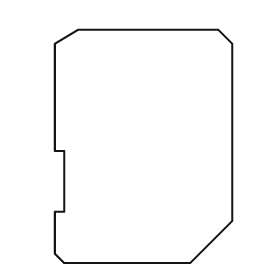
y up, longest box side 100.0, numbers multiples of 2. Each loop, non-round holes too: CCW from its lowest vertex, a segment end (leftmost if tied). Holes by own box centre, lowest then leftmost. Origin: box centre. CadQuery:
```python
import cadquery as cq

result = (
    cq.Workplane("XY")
    .moveTo(-34.0, -50.0)
    .lineTo(20.0, -50.0)
    .lineTo(38.0, -32.0)
    .lineTo(38.0, 44.0)
    .lineTo(32.0, 50.0)
    .lineTo(-28.0, 50.0)
    .lineTo(-38.0, 44.0)
    .lineTo(-38.0, -2.0)
    .lineTo(-34.0, -2.0)
    .lineTo(-34.0, -28.0)
    .lineTo(-38.0, -28.0)
    .lineTo(-38.0, -46.0)
    .close()
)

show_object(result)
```